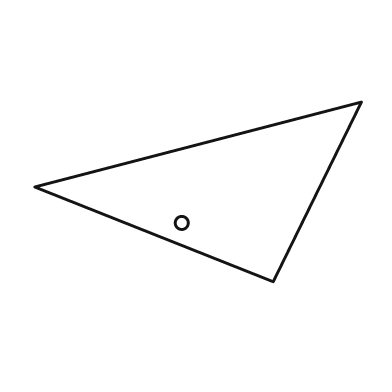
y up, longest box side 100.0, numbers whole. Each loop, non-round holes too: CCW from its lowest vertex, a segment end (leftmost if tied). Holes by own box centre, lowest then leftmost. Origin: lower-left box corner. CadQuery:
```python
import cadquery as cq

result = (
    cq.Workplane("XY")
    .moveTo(73.0, 0.0)
    .lineTo(100.0, 55.0)
    .lineTo(0.0, 29.0)
    .close()
    .moveTo(45.0, 18.0)
    .circle(2.0)
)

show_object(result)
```